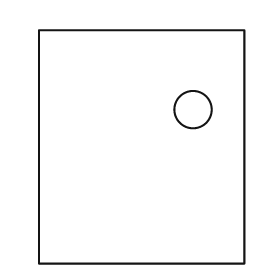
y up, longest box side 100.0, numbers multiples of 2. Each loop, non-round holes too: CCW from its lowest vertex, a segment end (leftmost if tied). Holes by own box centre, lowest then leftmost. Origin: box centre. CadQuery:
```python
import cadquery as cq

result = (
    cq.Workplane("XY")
    .moveTo(-44.0, -50.0)
    .lineTo(44.0, -50.0)
    .lineTo(44.0, 50.0)
    .lineTo(-44.0, 50.0)
    .close()
    .moveTo(22.0, 16.0)
    .circle(8.0)
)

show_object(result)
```